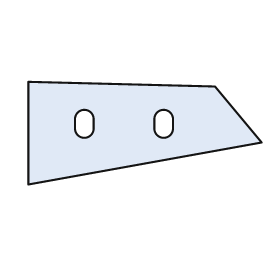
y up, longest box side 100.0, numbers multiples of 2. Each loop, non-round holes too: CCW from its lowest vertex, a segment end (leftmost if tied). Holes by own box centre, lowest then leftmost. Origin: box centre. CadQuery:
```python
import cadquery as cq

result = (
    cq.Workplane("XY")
    .moveTo(-50.0, -22.0)
    .lineTo(50.0, -4.0)
    .lineTo(30.0, 20.0)
    .lineTo(-50.0, 22.0)
    .close()
    .moveTo(-30.0, 2.0)
    .threePointArc((-26.0, -2.0), (-22.0, 2.0))
    .lineTo(-22.0, 6.0)
    .threePointArc((-26.0, 10.0), (-30.0, 6.0))
    .close()
    .moveTo(4.0, 2.0)
    .threePointArc((8.0, -2.0), (12.0, 2.0))
    .lineTo(12.0, 6.0)
    .threePointArc((8.0, 10.0), (4.0, 6.0))
    .close()
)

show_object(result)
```